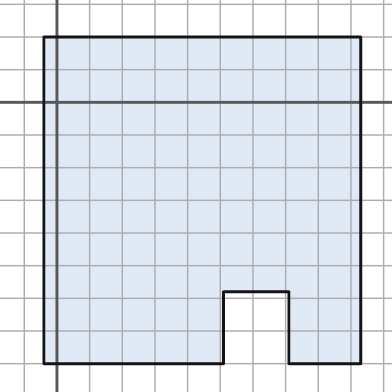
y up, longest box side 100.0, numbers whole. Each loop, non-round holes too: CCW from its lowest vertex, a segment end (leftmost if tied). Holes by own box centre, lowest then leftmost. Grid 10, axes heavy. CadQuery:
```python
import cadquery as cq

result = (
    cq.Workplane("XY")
    .moveTo(-4.0, -80.0)
    .lineTo(51.0, -80.0)
    .lineTo(51.0, -58.0)
    .lineTo(71.0, -58.0)
    .lineTo(71.0, -80.0)
    .lineTo(93.0, -80.0)
    .lineTo(93.0, 20.0)
    .lineTo(-4.0, 20.0)
    .close()
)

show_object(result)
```